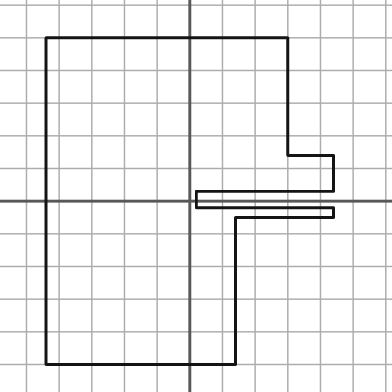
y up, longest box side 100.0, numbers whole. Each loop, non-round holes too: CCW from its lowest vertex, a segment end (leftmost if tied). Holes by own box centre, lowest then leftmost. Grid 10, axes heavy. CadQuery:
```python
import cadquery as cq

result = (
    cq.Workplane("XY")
    .moveTo(-44.0, -50.0)
    .lineTo(14.0, -50.0)
    .lineTo(14.0, -5.0)
    .lineTo(44.0, -5.0)
    .lineTo(44.0, -2.0)
    .lineTo(2.0, -2.0)
    .lineTo(2.0, 3.0)
    .lineTo(44.0, 3.0)
    .lineTo(44.0, 14.0)
    .lineTo(30.0, 14.0)
    .lineTo(30.0, 50.0)
    .lineTo(-44.0, 50.0)
    .close()
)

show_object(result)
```